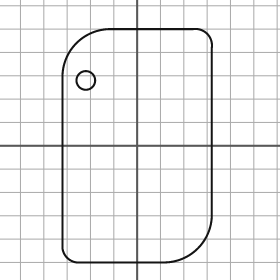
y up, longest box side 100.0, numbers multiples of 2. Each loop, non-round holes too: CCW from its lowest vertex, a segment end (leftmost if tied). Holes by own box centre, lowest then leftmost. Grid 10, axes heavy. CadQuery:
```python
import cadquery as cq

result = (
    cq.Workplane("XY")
    .moveTo(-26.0, -50.0)
    .lineTo(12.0, -50.0)
    .threePointArc((26.0, -44.0), (32.0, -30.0))
    .lineTo(32.0, 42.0)
    .threePointArc((30.0, 48.0), (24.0, 50.0))
    .lineTo(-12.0, 50.0)
    .threePointArc((-26.0, 44.0), (-32.0, 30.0))
    .lineTo(-32.0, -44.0)
    .threePointArc((-30.0, -48.0), (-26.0, -50.0))
    .close()
    .moveTo(-22.0, 28.0)
    .circle(4.0)
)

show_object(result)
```